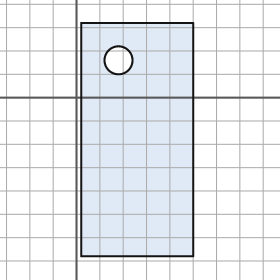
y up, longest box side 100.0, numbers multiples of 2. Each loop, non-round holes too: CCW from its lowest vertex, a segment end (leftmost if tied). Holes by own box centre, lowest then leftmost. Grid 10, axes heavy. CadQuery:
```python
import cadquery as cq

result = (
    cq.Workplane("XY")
    .moveTo(2.0, -68.0)
    .lineTo(50.0, -68.0)
    .lineTo(50.0, 32.0)
    .lineTo(2.0, 32.0)
    .close()
    .moveTo(18.0, 16.0)
    .circle(6.0)
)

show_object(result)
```